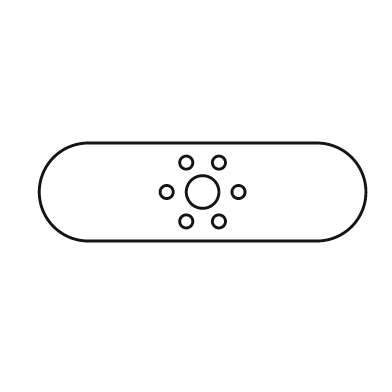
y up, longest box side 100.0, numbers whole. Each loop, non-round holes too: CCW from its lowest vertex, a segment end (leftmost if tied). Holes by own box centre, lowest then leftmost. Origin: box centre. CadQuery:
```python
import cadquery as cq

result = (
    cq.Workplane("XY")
    .moveTo(-35.0, -15.0)
    .lineTo(35.0, -15.0)
    .threePointArc((50.0, 0.0), (35.0, 15.0))
    .lineTo(-35.0, 15.0)
    .threePointArc((-50.0, 0.0), (-35.0, -15.0))
    .close()
    .moveTo(-5.0, -9.0)
    .circle(2.0)
    .moveTo(5.0, -9.0)
    .circle(2.0)
    .moveTo(-11.0, 0.0)
    .circle(2.0)
    .moveTo(0.0, 0.0)
    .circle(5.0)
    .moveTo(11.0, 0.0)
    .circle(2.0)
    .moveTo(-5.0, 9.0)
    .circle(2.0)
    .moveTo(5.0, 9.0)
    .circle(2.0)
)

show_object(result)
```